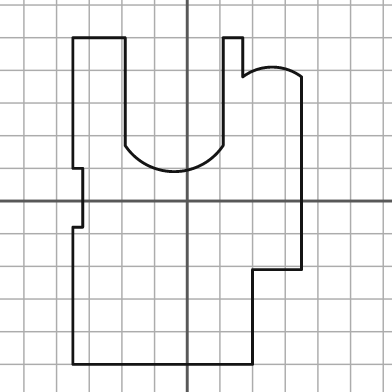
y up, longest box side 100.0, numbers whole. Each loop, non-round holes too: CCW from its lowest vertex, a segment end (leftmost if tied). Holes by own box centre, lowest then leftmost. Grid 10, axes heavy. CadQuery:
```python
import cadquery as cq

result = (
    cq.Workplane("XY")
    .moveTo(-35.0, -50.0)
    .lineTo(20.0, -50.0)
    .lineTo(20.0, -21.0)
    .lineTo(35.0, -21.0)
    .lineTo(35.0, 38.0)
    .threePointArc((26.0, 41.0), (17.0, 38.0))
    .lineTo(17.0, 50.0)
    .lineTo(11.0, 50.0)
    .lineTo(11.0, 17.0)
    .threePointArc((-4.0, 9.0), (-19.0, 17.0))
    .lineTo(-19.0, 50.0)
    .lineTo(-35.0, 50.0)
    .lineTo(-35.0, 10.0)
    .lineTo(-32.0, 10.0)
    .lineTo(-32.0, -8.0)
    .lineTo(-35.0, -8.0)
    .close()
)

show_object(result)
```